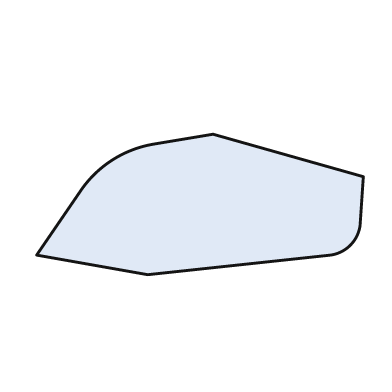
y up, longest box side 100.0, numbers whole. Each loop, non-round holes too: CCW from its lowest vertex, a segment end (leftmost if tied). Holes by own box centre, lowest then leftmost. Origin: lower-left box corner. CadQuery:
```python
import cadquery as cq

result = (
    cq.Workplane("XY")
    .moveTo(34.0, 0.0)
    .lineTo(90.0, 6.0)
    .threePointArc((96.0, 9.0), (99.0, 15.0))
    .lineTo(100.0, 30.0)
    .lineTo(54.0, 43.0)
    .lineTo(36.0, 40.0)
    .threePointArc((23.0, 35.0), (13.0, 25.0))
    .lineTo(0.0, 6.0)
    .close()
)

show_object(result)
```